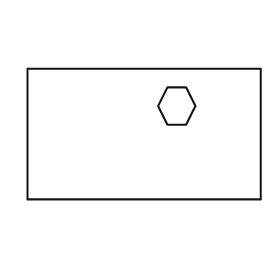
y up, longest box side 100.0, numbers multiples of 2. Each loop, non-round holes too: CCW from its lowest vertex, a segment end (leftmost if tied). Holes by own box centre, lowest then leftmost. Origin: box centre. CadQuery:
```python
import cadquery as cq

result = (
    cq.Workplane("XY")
    .moveTo(-50.0, -28.0)
    .lineTo(50.0, -28.0)
    .lineTo(50.0, 28.0)
    .lineTo(-50.0, 28.0)
    .close()
    .moveTo(10.0, 4.0)
    .lineTo(18.0, 4.0)
    .lineTo(22.0, 12.0)
    .lineTo(18.0, 20.0)
    .lineTo(10.0, 20.0)
    .lineTo(6.0, 12.0)
    .close()
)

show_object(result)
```